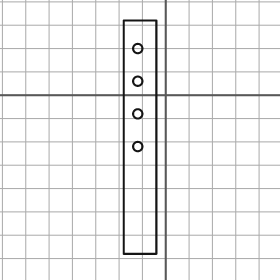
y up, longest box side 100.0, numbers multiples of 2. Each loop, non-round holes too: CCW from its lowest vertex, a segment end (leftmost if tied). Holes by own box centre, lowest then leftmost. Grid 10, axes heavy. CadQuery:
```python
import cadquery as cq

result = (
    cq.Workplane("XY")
    .moveTo(-18.0, -68.0)
    .lineTo(-4.0, -68.0)
    .lineTo(-4.0, 32.0)
    .lineTo(-18.0, 32.0)
    .close()
    .moveTo(-12.0, -22.0)
    .circle(2.0)
    .moveTo(-12.0, -8.0)
    .circle(2.0)
    .moveTo(-12.0, 6.0)
    .circle(2.0)
    .moveTo(-12.0, 20.0)
    .circle(2.0)
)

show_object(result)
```